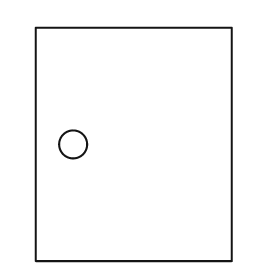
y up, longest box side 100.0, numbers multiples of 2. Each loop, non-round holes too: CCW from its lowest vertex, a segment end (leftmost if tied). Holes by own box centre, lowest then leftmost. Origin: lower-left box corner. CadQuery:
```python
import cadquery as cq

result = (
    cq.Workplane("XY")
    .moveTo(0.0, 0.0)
    .lineTo(84.0, 0.0)
    .lineTo(84.0, 100.0)
    .lineTo(0.0, 100.0)
    .close()
    .moveTo(16.0, 50.0)
    .circle(6.0)
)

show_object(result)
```